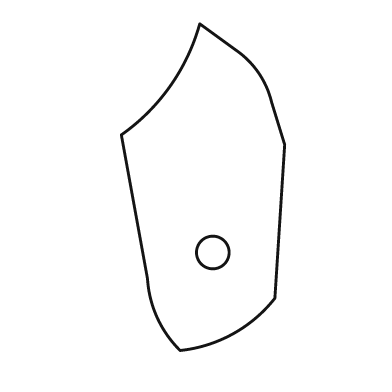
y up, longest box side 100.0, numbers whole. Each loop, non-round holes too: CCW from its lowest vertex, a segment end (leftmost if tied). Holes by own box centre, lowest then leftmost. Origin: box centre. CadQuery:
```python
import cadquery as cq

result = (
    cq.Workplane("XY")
    .moveTo(-7.0, -50.0)
    .threePointArc((9.0, -45.0), (22.0, -34.0))
    .lineTo(25.0, 13.0)
    .lineTo(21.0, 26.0)
    .threePointArc((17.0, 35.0), (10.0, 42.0))
    .lineTo(-1.0, 50.0)
    .threePointArc((-10.0, 31.0), (-25.0, 16.0))
    .lineTo(-17.0, -28.0)
    .threePointArc((-14.0, -40.0), (-7.0, -50.0))
    .close()
    .moveTo(3.0, -20.0)
    .circle(5.0)
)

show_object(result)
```